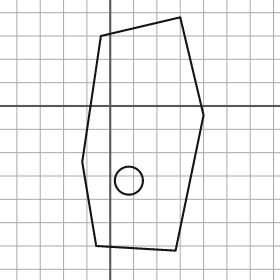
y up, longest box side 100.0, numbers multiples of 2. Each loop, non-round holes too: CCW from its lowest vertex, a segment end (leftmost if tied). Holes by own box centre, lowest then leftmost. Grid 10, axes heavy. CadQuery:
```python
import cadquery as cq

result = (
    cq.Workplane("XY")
    .moveTo(28.0, -62.0)
    .lineTo(40.0, -4.0)
    .lineTo(30.0, 38.0)
    .lineTo(-4.0, 30.0)
    .lineTo(-12.0, -24.0)
    .lineTo(-6.0, -60.0)
    .close()
    .moveTo(8.0, -32.0)
    .circle(6.0)
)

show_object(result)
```